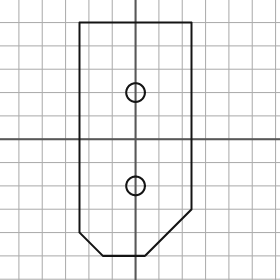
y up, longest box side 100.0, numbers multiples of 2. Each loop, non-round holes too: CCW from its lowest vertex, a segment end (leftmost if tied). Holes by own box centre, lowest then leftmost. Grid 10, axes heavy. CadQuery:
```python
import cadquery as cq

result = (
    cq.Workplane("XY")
    .moveTo(-14.0, -50.0)
    .lineTo(4.0, -50.0)
    .lineTo(24.0, -30.0)
    .lineTo(24.0, 50.0)
    .lineTo(-24.0, 50.0)
    .lineTo(-24.0, -40.0)
    .close()
    .moveTo(0.0, -20.0)
    .circle(4.0)
    .moveTo(0.0, 20.0)
    .circle(4.0)
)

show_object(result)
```